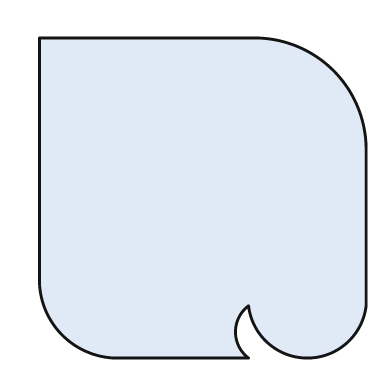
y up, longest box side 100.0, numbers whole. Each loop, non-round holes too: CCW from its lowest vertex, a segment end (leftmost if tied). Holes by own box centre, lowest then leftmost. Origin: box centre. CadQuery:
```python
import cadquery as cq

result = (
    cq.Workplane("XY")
    .moveTo(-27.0, -49.0)
    .lineTo(14.0, -49.0)
    .threePointArc((10.0, -41.0), (14.0, -33.0))
    .threePointArc((32.0, -49.0), (50.0, -33.0))
    .lineTo(50.0, 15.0)
    .threePointArc((40.0, 39.0), (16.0, 49.0))
    .lineTo(-50.0, 49.0)
    .lineTo(-50.0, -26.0)
    .threePointArc((-43.0, -42.0), (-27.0, -49.0))
    .close()
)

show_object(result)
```